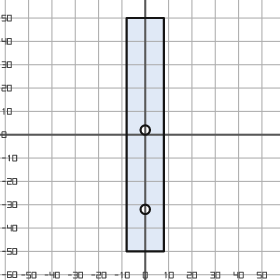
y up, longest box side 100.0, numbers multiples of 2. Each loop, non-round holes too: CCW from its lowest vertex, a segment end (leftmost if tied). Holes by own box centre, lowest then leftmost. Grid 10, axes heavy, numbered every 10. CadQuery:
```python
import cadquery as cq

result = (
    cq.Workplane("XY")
    .moveTo(-8.0, -50.0)
    .lineTo(8.0, -50.0)
    .lineTo(8.0, 50.0)
    .lineTo(-8.0, 50.0)
    .close()
    .moveTo(0.0, -32.0)
    .circle(2.0)
    .moveTo(0.0, 2.0)
    .circle(2.0)
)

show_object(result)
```